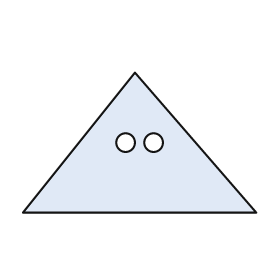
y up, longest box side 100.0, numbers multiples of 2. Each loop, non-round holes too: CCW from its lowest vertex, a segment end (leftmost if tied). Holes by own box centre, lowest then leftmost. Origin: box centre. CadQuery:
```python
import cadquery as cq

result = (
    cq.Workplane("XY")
    .moveTo(-50.0, -30.0)
    .lineTo(50.0, -30.0)
    .lineTo(-2.0, 30.0)
    .close()
    .moveTo(-6.0, 0.0)
    .circle(4.0)
    .moveTo(6.0, 0.0)
    .circle(4.0)
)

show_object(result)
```